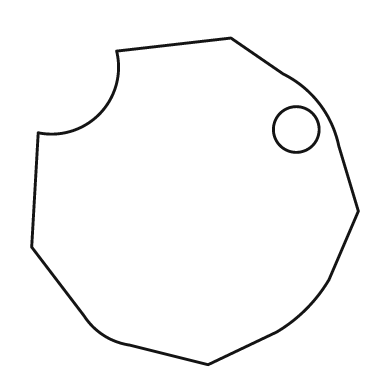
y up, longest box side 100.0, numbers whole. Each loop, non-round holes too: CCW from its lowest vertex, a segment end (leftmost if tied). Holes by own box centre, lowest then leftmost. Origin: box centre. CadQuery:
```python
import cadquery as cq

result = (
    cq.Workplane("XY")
    .moveTo(4.0, -50.0)
    .lineTo(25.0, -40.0)
    .threePointArc((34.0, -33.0), (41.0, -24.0))
    .lineTo(50.0, -3.0)
    .lineTo(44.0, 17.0)
    .threePointArc((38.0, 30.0), (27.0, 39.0))
    .lineTo(11.0, 50.0)
    .lineTo(-24.0, 46.0)
    .threePointArc((-29.0, 27.0), (-48.0, 21.0))
    .lineTo(-50.0, -14.0)
    .lineTo(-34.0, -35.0)
    .threePointArc((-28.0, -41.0), (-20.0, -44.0))
    .close()
    .moveTo(31.0, 22.0)
    .circle(7.0)
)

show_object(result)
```